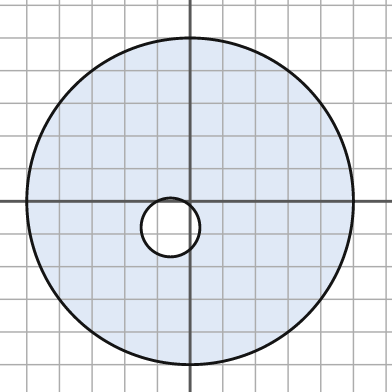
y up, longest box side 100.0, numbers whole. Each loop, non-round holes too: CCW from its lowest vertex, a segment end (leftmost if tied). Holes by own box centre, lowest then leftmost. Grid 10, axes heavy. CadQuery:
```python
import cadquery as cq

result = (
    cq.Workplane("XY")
    .moveTo(0.0, 0.0)
    .circle(50.0)
    .moveTo(-6.0, -8.0)
    .circle(9.0)
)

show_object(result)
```